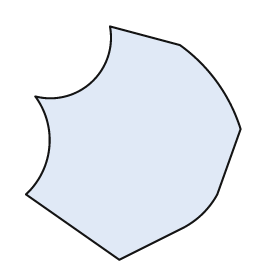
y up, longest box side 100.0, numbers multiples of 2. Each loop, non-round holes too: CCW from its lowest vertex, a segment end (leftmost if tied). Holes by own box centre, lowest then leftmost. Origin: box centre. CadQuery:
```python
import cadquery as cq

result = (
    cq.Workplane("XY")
    .moveTo(-6.0, -50.0)
    .lineTo(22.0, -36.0)
    .threePointArc((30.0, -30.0), (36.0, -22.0))
    .lineTo(46.0, 6.0)
    .threePointArc((36.0, 26.0), (20.0, 42.0))
    .lineTo(-10.0, 50.0)
    .threePointArc((-18.0, 26.0), (-42.0, 20.0))
    .threePointArc((-36.0, -2.0), (-46.0, -22.0))
    .close()
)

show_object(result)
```